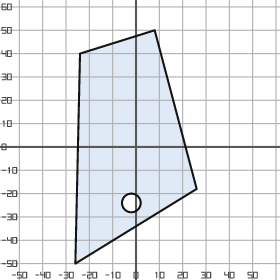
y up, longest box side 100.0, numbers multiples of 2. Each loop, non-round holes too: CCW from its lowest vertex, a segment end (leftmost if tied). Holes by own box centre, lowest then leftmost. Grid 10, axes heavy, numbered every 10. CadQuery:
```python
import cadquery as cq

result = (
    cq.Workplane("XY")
    .moveTo(-26.0, -50.0)
    .lineTo(26.0, -18.0)
    .lineTo(8.0, 50.0)
    .lineTo(-24.0, 40.0)
    .close()
    .moveTo(-2.0, -24.0)
    .circle(4.0)
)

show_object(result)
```